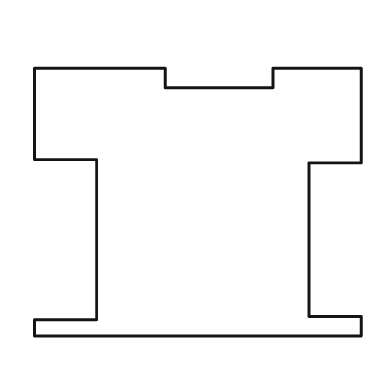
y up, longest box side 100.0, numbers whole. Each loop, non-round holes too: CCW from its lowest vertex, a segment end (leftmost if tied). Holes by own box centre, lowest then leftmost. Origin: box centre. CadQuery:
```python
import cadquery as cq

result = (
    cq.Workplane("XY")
    .moveTo(-50.0, -41.0)
    .lineTo(50.0, -41.0)
    .lineTo(50.0, -35.0)
    .lineTo(34.0, -35.0)
    .lineTo(34.0, 12.0)
    .lineTo(50.0, 12.0)
    .lineTo(50.0, 41.0)
    .lineTo(23.0, 41.0)
    .lineTo(23.0, 35.0)
    .lineTo(-10.0, 35.0)
    .lineTo(-10.0, 41.0)
    .lineTo(-50.0, 41.0)
    .lineTo(-50.0, 13.0)
    .lineTo(-31.0, 13.0)
    .lineTo(-31.0, -36.0)
    .lineTo(-50.0, -36.0)
    .close()
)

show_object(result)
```